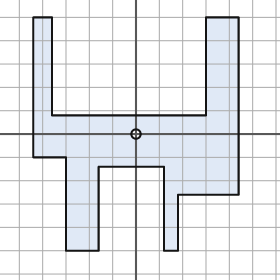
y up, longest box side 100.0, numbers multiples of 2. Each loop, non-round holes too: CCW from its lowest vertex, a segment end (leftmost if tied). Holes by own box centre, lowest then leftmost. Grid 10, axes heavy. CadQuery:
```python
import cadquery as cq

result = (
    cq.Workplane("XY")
    .moveTo(-30.0, -50.0)
    .lineTo(-16.0, -50.0)
    .lineTo(-16.0, -14.0)
    .lineTo(12.0, -14.0)
    .lineTo(12.0, -50.0)
    .lineTo(18.0, -50.0)
    .lineTo(18.0, -26.0)
    .lineTo(44.0, -26.0)
    .lineTo(44.0, 50.0)
    .lineTo(30.0, 50.0)
    .lineTo(30.0, 8.0)
    .lineTo(-36.0, 8.0)
    .lineTo(-36.0, 50.0)
    .lineTo(-44.0, 50.0)
    .lineTo(-44.0, -10.0)
    .lineTo(-30.0, -10.0)
    .close()
    .moveTo(0.0, 0.0)
    .circle(2.0)
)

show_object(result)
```